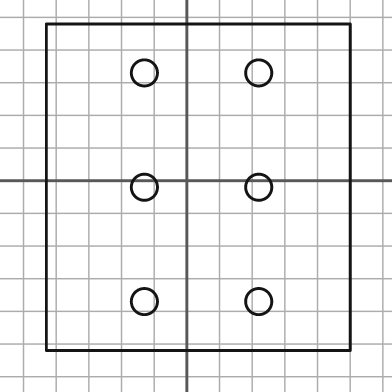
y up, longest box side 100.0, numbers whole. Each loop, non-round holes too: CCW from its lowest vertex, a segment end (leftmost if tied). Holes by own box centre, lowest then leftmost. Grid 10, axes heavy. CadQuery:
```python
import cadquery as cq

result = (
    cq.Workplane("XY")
    .moveTo(-43.0, -52.0)
    .lineTo(50.0, -52.0)
    .lineTo(50.0, 48.0)
    .lineTo(-43.0, 48.0)
    .close()
    .moveTo(-13.0, -37.0)
    .circle(4.0)
    .moveTo(22.0, -37.0)
    .circle(4.0)
    .moveTo(-13.0, -2.0)
    .circle(4.0)
    .moveTo(22.0, -2.0)
    .circle(4.0)
    .moveTo(-13.0, 33.0)
    .circle(4.0)
    .moveTo(22.0, 33.0)
    .circle(4.0)
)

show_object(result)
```